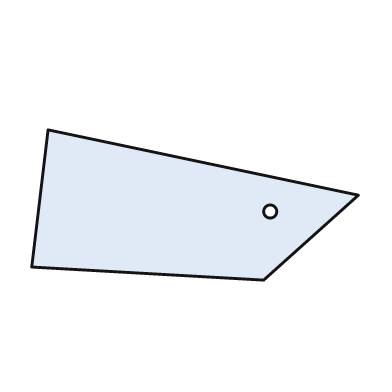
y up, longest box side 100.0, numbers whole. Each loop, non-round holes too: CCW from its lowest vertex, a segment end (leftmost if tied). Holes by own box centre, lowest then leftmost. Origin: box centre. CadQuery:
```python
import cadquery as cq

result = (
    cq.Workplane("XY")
    .moveTo(21.0, -23.0)
    .lineTo(50.0, 3.0)
    .lineTo(-45.0, 23.0)
    .lineTo(-50.0, -19.0)
    .close()
    .moveTo(23.0, -2.0)
    .circle(2.0)
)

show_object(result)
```